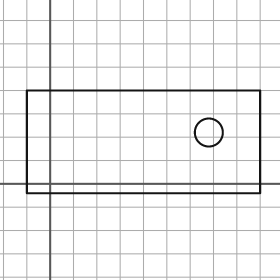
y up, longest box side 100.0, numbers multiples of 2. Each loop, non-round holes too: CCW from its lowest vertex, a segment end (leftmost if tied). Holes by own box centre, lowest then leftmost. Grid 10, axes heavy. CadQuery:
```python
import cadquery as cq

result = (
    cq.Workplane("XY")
    .moveTo(-10.0, -4.0)
    .lineTo(90.0, -4.0)
    .lineTo(90.0, 40.0)
    .lineTo(-10.0, 40.0)
    .close()
    .moveTo(68.0, 22.0)
    .circle(6.0)
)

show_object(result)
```